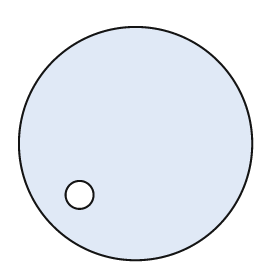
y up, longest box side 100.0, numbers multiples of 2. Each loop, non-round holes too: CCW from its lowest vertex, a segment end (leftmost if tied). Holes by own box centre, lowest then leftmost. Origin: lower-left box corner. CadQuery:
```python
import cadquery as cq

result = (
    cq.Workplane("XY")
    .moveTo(50.0, 50.0)
    .circle(50.0)
    .moveTo(26.0, 28.0)
    .circle(6.0)
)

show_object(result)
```